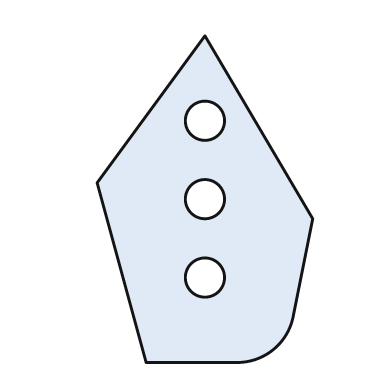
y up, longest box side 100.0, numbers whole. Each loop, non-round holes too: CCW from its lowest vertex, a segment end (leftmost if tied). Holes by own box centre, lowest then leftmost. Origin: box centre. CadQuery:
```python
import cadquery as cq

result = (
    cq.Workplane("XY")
    .moveTo(-18.0, -50.0)
    .lineTo(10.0, -50.0)
    .threePointArc((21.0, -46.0), (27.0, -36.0))
    .lineTo(33.0, -6.0)
    .lineTo(0.0, 50.0)
    .lineTo(-33.0, 5.0)
    .close()
    .moveTo(0.0, -24.0)
    .circle(6.0)
    .moveTo(0.0, 0.0)
    .circle(6.0)
    .moveTo(0.0, 24.0)
    .circle(6.0)
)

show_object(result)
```